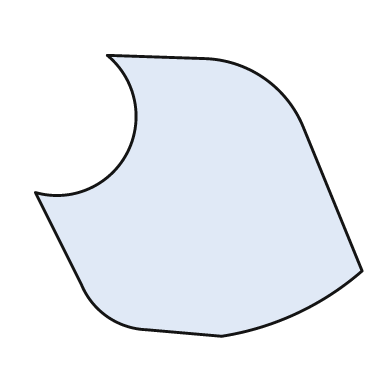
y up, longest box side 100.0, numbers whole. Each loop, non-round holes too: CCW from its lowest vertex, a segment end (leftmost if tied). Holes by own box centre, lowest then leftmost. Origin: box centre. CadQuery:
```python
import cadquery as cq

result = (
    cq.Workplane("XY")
    .moveTo(7.0, -43.0)
    .threePointArc((30.0, -36.0), (50.0, -23.0))
    .lineTo(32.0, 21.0)
    .threePointArc((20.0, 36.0), (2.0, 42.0))
    .lineTo(-28.0, 43.0)
    .threePointArc((-22.0, 13.0), (-50.0, 1.0))
    .lineTo(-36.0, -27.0)
    .threePointArc((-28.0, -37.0), (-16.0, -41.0))
    .close()
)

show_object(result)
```